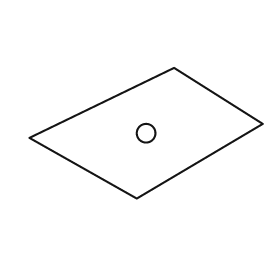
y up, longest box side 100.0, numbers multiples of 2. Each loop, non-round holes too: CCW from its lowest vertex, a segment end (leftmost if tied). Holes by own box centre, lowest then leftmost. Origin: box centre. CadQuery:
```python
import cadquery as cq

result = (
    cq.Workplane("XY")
    .moveTo(-4.0, -28.0)
    .lineTo(50.0, 4.0)
    .lineTo(12.0, 28.0)
    .lineTo(-50.0, -2.0)
    .close()
    .moveTo(0.0, 0.0)
    .circle(4.0)
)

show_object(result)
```